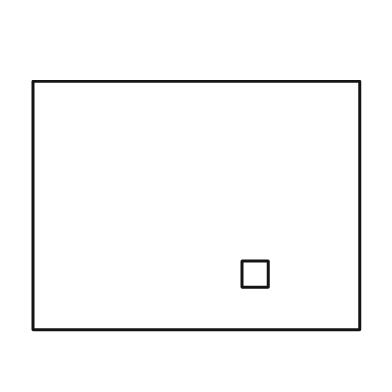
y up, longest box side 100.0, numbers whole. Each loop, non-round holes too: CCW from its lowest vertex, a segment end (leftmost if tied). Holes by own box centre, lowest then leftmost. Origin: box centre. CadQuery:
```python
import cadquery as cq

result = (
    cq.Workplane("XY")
    .moveTo(-50.0, -38.0)
    .lineTo(50.0, -38.0)
    .lineTo(50.0, 38.0)
    .lineTo(-50.0, 38.0)
    .close()
    .moveTo(14.0, -25.0)
    .lineTo(22.0, -25.0)
    .lineTo(22.0, -17.0)
    .lineTo(14.0, -17.0)
    .close()
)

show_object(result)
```